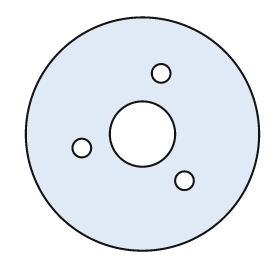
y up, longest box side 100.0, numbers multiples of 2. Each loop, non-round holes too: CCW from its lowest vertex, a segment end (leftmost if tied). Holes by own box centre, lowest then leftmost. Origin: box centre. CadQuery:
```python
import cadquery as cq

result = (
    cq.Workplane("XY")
    .moveTo(0.0, 0.0)
    .circle(50.0)
    .moveTo(18.0, -20.0)
    .circle(4.0)
    .moveTo(-26.0, -6.0)
    .circle(4.0)
    .moveTo(0.0, 0.0)
    .circle(14.0)
    .moveTo(8.0, 26.0)
    .circle(4.0)
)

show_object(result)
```